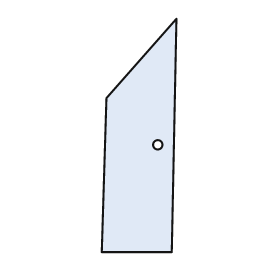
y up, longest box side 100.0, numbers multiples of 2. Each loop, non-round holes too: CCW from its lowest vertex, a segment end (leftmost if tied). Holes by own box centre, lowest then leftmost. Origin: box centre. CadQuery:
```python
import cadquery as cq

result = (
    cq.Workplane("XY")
    .moveTo(-16.0, -50.0)
    .lineTo(14.0, -50.0)
    .lineTo(16.0, 50.0)
    .lineTo(-14.0, 16.0)
    .close()
    .moveTo(8.0, -4.0)
    .circle(2.0)
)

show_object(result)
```